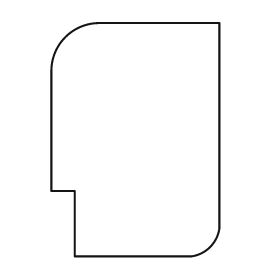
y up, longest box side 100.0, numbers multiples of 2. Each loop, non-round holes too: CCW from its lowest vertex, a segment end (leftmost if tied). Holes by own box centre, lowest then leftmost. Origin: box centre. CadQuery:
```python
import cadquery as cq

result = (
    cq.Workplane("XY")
    .moveTo(-26.0, -50.0)
    .lineTo(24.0, -50.0)
    .threePointArc((32.0, -46.0), (36.0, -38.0))
    .lineTo(36.0, 50.0)
    .lineTo(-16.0, 50.0)
    .threePointArc((-30.0, 44.0), (-36.0, 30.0))
    .lineTo(-36.0, -22.0)
    .lineTo(-26.0, -22.0)
    .close()
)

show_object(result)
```